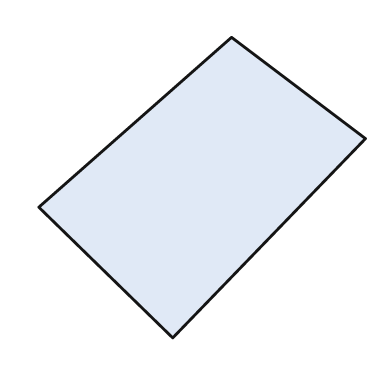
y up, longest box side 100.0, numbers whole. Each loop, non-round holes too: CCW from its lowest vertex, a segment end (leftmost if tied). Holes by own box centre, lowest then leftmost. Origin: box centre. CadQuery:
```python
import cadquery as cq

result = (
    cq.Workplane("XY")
    .moveTo(-9.0, -46.0)
    .lineTo(50.0, 15.0)
    .lineTo(9.0, 46.0)
    .lineTo(-50.0, -6.0)
    .close()
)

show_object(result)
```